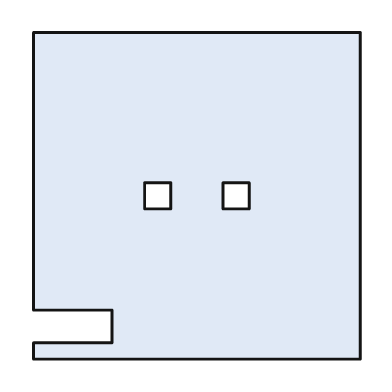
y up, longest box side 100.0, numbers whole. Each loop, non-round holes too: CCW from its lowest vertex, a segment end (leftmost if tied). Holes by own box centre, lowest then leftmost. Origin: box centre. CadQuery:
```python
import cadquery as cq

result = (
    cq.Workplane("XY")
    .moveTo(-50.0, -50.0)
    .lineTo(50.0, -50.0)
    .lineTo(50.0, 50.0)
    .lineTo(-50.0, 50.0)
    .lineTo(-50.0, -35.0)
    .lineTo(-26.0, -35.0)
    .lineTo(-26.0, -45.0)
    .lineTo(-50.0, -45.0)
    .close()
    .moveTo(-16.0, -4.0)
    .lineTo(-8.0, -4.0)
    .lineTo(-8.0, 4.0)
    .lineTo(-16.0, 4.0)
    .close()
    .moveTo(8.0, -4.0)
    .lineTo(16.0, -4.0)
    .lineTo(16.0, 4.0)
    .lineTo(8.0, 4.0)
    .close()
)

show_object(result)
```